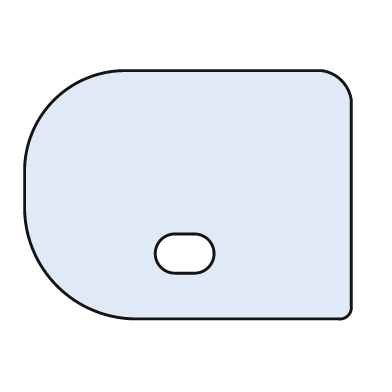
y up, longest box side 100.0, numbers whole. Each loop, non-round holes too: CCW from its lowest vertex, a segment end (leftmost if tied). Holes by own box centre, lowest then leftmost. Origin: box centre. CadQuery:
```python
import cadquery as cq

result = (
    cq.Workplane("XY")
    .moveTo(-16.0, -38.0)
    .lineTo(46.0, -38.0)
    .threePointArc((49.0, -37.0), (50.0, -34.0))
    .lineTo(50.0, 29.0)
    .threePointArc((47.0, 35.0), (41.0, 38.0))
    .lineTo(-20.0, 38.0)
    .threePointArc((-41.0, 29.0), (-50.0, 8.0))
    .lineTo(-50.0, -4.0)
    .threePointArc((-40.0, -28.0), (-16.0, -38.0))
    .close()
    .moveTo(-4.0, -24.0)
    .lineTo(2.0, -24.0)
    .threePointArc((8.0, -18.0), (2.0, -12.0))
    .lineTo(-4.0, -12.0)
    .threePointArc((-10.0, -18.0), (-4.0, -24.0))
    .close()
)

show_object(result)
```